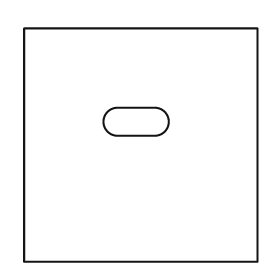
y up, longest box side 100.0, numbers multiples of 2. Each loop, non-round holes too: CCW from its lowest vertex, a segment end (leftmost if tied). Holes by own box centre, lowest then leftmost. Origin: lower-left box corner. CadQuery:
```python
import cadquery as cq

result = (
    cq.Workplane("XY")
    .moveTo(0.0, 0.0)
    .lineTo(100.0, 0.0)
    .lineTo(100.0, 100.0)
    .lineTo(0.0, 100.0)
    .close()
    .moveTo(40.0, 54.0)
    .lineTo(56.0, 54.0)
    .threePointArc((62.0, 60.0), (56.0, 66.0))
    .lineTo(40.0, 66.0)
    .threePointArc((34.0, 60.0), (40.0, 54.0))
    .close()
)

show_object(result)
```